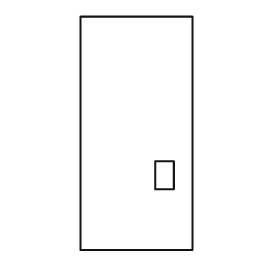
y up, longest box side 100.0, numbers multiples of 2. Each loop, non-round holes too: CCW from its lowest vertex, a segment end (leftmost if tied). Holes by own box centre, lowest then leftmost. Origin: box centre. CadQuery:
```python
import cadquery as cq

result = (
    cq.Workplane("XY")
    .moveTo(-24.0, -50.0)
    .lineTo(24.0, -50.0)
    .lineTo(24.0, 50.0)
    .lineTo(-24.0, 50.0)
    .close()
    .moveTo(8.0, -24.0)
    .lineTo(16.0, -24.0)
    .lineTo(16.0, -12.0)
    .lineTo(8.0, -12.0)
    .close()
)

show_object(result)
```